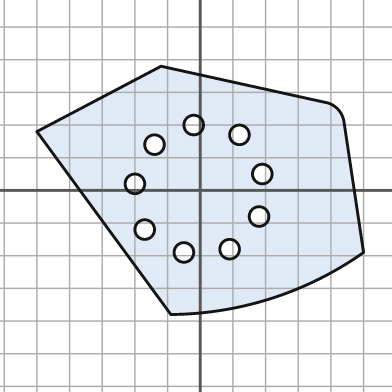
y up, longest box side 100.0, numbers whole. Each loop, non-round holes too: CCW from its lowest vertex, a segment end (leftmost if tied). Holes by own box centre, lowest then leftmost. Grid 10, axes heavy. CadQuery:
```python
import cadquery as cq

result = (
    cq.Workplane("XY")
    .moveTo(-9.0, -38.0)
    .threePointArc((22.0, -33.0), (50.0, -19.0))
    .lineTo(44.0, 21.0)
    .threePointArc((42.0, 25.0), (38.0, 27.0))
    .lineTo(-12.0, 38.0)
    .lineTo(-50.0, 18.0)
    .close()
    .moveTo(-5.0, -19.0)
    .circle(3.0)
    .moveTo(9.0, -18.0)
    .circle(3.0)
    .moveTo(-17.0, -12.0)
    .circle(3.0)
    .moveTo(18.0, -8.0)
    .circle(3.0)
    .moveTo(-20.0, 2.0)
    .circle(3.0)
    .moveTo(19.0, 5.0)
    .circle(3.0)
    .moveTo(-14.0, 14.0)
    .circle(3.0)
    .moveTo(12.0, 17.0)
    .circle(3.0)
    .moveTo(-2.0, 20.0)
    .circle(3.0)
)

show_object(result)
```